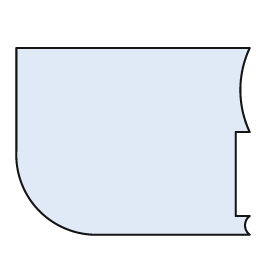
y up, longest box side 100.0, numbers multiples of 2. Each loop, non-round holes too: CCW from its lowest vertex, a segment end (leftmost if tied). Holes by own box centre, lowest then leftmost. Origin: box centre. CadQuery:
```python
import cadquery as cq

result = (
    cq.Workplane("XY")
    .moveTo(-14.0, -40.0)
    .lineTo(50.0, -40.0)
    .threePointArc((48.0, -36.0), (50.0, -32.0))
    .lineTo(44.0, -32.0)
    .lineTo(44.0, 4.0)
    .lineTo(50.0, 4.0)
    .threePointArc((46.0, 22.0), (50.0, 40.0))
    .lineTo(-50.0, 40.0)
    .lineTo(-50.0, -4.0)
    .threePointArc((-40.0, -30.0), (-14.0, -40.0))
    .close()
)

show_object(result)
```